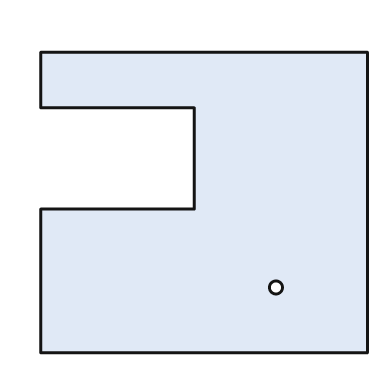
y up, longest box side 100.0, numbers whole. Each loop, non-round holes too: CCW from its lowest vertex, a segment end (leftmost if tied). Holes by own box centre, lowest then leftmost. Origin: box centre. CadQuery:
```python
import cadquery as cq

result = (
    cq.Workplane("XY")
    .moveTo(-50.0, -46.0)
    .lineTo(50.0, -46.0)
    .lineTo(50.0, 46.0)
    .lineTo(-50.0, 46.0)
    .lineTo(-50.0, 29.0)
    .lineTo(-3.0, 29.0)
    .lineTo(-3.0, -2.0)
    .lineTo(-50.0, -2.0)
    .close()
    .moveTo(22.0, -26.0)
    .circle(2.0)
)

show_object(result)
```